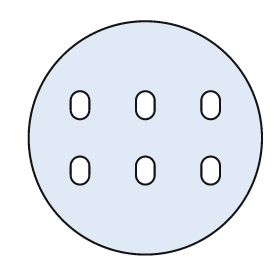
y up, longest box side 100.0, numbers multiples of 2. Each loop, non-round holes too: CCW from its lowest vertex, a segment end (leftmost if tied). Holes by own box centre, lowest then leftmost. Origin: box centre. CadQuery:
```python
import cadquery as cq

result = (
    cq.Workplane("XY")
    .moveTo(0.0, 0.0)
    .circle(50.0)
    .moveTo(-32.0, -16.0)
    .threePointArc((-28.0, -20.0), (-24.0, -16.0))
    .lineTo(-24.0, -12.0)
    .threePointArc((-28.0, -8.0), (-32.0, -12.0))
    .close()
    .moveTo(-4.0, -16.0)
    .threePointArc((0.0, -20.0), (4.0, -16.0))
    .lineTo(4.0, -12.0)
    .threePointArc((0.0, -8.0), (-4.0, -12.0))
    .close()
    .moveTo(24.0, -16.0)
    .threePointArc((28.0, -20.0), (32.0, -16.0))
    .lineTo(32.0, -12.0)
    .threePointArc((28.0, -8.0), (24.0, -12.0))
    .close()
    .moveTo(-32.0, 12.0)
    .threePointArc((-28.0, 8.0), (-24.0, 12.0))
    .lineTo(-24.0, 16.0)
    .threePointArc((-28.0, 20.0), (-32.0, 16.0))
    .close()
    .moveTo(-4.0, 12.0)
    .threePointArc((0.0, 8.0), (4.0, 12.0))
    .lineTo(4.0, 16.0)
    .threePointArc((0.0, 20.0), (-4.0, 16.0))
    .close()
    .moveTo(24.0, 12.0)
    .threePointArc((28.0, 8.0), (32.0, 12.0))
    .lineTo(32.0, 16.0)
    .threePointArc((28.0, 20.0), (24.0, 16.0))
    .close()
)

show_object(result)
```